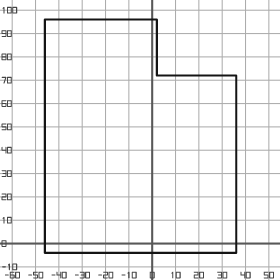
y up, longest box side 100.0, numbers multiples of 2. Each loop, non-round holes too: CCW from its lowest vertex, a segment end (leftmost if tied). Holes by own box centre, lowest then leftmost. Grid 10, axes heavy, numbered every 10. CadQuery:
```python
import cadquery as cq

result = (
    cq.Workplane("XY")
    .moveTo(-46.0, -4.0)
    .lineTo(36.0, -4.0)
    .lineTo(36.0, 72.0)
    .lineTo(2.0, 72.0)
    .lineTo(2.0, 96.0)
    .lineTo(-46.0, 96.0)
    .close()
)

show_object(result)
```